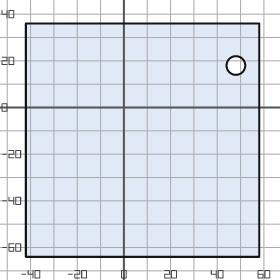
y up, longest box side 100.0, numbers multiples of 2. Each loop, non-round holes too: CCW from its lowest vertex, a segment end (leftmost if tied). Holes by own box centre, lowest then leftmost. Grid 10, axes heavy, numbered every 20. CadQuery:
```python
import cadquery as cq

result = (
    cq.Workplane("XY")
    .moveTo(-42.0, -64.0)
    .lineTo(58.0, -64.0)
    .lineTo(58.0, 36.0)
    .lineTo(-42.0, 36.0)
    .close()
    .moveTo(48.0, 18.0)
    .circle(4.0)
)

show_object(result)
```